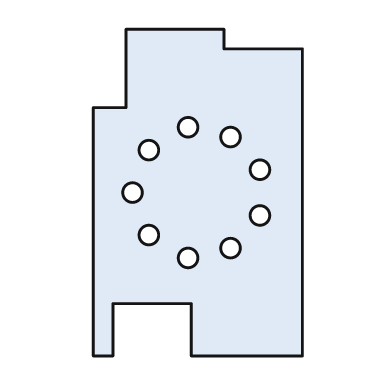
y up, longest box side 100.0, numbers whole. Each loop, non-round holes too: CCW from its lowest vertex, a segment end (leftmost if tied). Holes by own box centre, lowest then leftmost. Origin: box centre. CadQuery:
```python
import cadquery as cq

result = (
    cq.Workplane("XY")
    .moveTo(-32.0, -50.0)
    .lineTo(-26.0, -50.0)
    .lineTo(-26.0, -34.0)
    .lineTo(-2.0, -34.0)
    .lineTo(-2.0, -50.0)
    .lineTo(32.0, -50.0)
    .lineTo(32.0, 44.0)
    .lineTo(8.0, 44.0)
    .lineTo(8.0, 50.0)
    .lineTo(-22.0, 50.0)
    .lineTo(-22.0, 26.0)
    .lineTo(-32.0, 26.0)
    .close()
    .moveTo(-3.0, -20.0)
    .circle(3.0)
    .moveTo(10.0, -17.0)
    .circle(3.0)
    .moveTo(-15.0, -13.0)
    .circle(3.0)
    .moveTo(19.0, -7.0)
    .circle(3.0)
    .moveTo(-20.0, 0.0)
    .circle(3.0)
    .moveTo(19.0, 7.0)
    .circle(3.0)
    .moveTo(-15.0, 13.0)
    .circle(3.0)
    .moveTo(10.0, 17.0)
    .circle(3.0)
    .moveTo(-3.0, 20.0)
    .circle(3.0)
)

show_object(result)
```